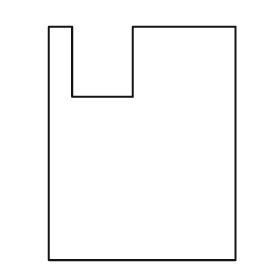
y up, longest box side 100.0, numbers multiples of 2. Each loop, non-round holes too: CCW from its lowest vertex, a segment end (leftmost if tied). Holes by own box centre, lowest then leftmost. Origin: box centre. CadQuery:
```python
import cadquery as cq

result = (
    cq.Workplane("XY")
    .moveTo(-40.0, -50.0)
    .lineTo(40.0, -50.0)
    .lineTo(40.0, 50.0)
    .lineTo(-4.0, 50.0)
    .lineTo(-4.0, 20.0)
    .lineTo(-30.0, 20.0)
    .lineTo(-30.0, 50.0)
    .lineTo(-40.0, 50.0)
    .close()
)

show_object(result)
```